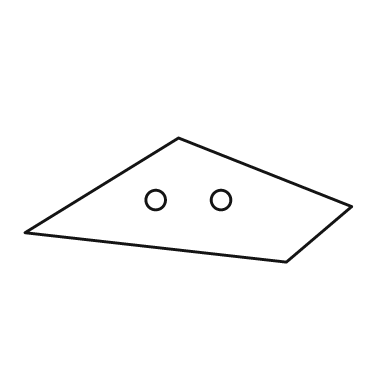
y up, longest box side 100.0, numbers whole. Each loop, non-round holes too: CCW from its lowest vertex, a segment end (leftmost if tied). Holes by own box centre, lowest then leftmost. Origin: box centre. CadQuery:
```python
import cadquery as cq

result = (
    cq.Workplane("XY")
    .moveTo(30.0, -19.0)
    .lineTo(50.0, -2.0)
    .lineTo(-3.0, 19.0)
    .lineTo(-50.0, -10.0)
    .close()
    .moveTo(-10.0, 0.0)
    .circle(3.0)
    .moveTo(10.0, 0.0)
    .circle(3.0)
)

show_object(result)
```